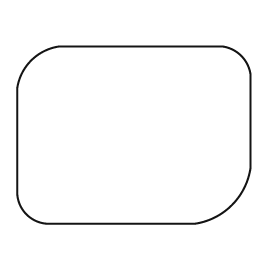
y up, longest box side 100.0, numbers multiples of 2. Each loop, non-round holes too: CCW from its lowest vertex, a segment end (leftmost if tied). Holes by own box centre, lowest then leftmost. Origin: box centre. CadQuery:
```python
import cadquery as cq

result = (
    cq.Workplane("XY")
    .moveTo(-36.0, -38.0)
    .lineTo(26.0, -38.0)
    .threePointArc((42.0, -30.0), (50.0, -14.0))
    .lineTo(50.0, 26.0)
    .threePointArc((46.0, 34.0), (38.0, 38.0))
    .lineTo(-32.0, 38.0)
    .threePointArc((-44.0, 32.0), (-50.0, 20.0))
    .lineTo(-50.0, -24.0)
    .threePointArc((-46.0, -34.0), (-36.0, -38.0))
    .close()
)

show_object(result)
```